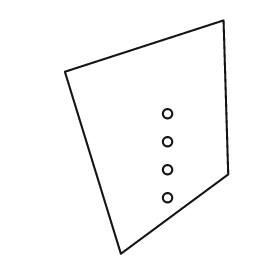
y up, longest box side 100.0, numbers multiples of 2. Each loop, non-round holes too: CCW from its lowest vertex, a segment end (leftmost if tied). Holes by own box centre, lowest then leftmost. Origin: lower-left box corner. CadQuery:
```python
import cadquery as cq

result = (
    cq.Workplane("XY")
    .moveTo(24.0, 0.0)
    .lineTo(70.0, 34.0)
    .lineTo(68.0, 100.0)
    .lineTo(0.0, 78.0)
    .close()
    .moveTo(44.0, 24.0)
    .circle(2.0)
    .moveTo(44.0, 36.0)
    .circle(2.0)
    .moveTo(44.0, 48.0)
    .circle(2.0)
    .moveTo(44.0, 60.0)
    .circle(2.0)
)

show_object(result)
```